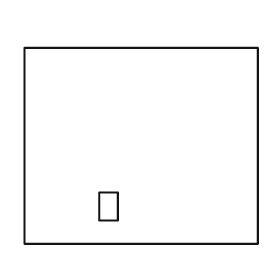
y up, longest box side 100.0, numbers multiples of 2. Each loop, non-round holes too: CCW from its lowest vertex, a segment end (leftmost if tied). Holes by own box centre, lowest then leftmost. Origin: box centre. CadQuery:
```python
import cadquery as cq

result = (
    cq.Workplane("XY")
    .moveTo(-50.0, -42.0)
    .lineTo(50.0, -42.0)
    .lineTo(50.0, 42.0)
    .lineTo(-50.0, 42.0)
    .close()
    .moveTo(-18.0, -32.0)
    .lineTo(-10.0, -32.0)
    .lineTo(-10.0, -20.0)
    .lineTo(-18.0, -20.0)
    .close()
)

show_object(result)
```